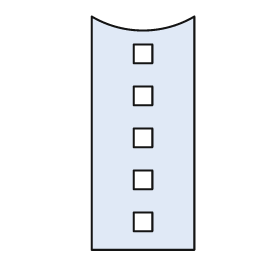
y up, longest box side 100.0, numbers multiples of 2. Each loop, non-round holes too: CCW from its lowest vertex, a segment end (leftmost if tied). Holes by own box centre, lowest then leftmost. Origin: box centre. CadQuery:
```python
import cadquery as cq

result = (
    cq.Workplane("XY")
    .moveTo(-22.0, -50.0)
    .lineTo(22.0, -50.0)
    .lineTo(22.0, 50.0)
    .threePointArc((0.0, 44.0), (-22.0, 50.0))
    .close()
    .moveTo(-4.0, -42.0)
    .lineTo(4.0, -42.0)
    .lineTo(4.0, -34.0)
    .lineTo(-4.0, -34.0)
    .close()
    .moveTo(-4.0, -24.0)
    .lineTo(4.0, -24.0)
    .lineTo(4.0, -16.0)
    .lineTo(-4.0, -16.0)
    .close()
    .moveTo(-4.0, -6.0)
    .lineTo(4.0, -6.0)
    .lineTo(4.0, 2.0)
    .lineTo(-4.0, 2.0)
    .close()
    .moveTo(-4.0, 12.0)
    .lineTo(4.0, 12.0)
    .lineTo(4.0, 20.0)
    .lineTo(-4.0, 20.0)
    .close()
    .moveTo(-4.0, 30.0)
    .lineTo(4.0, 30.0)
    .lineTo(4.0, 38.0)
    .lineTo(-4.0, 38.0)
    .close()
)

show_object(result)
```